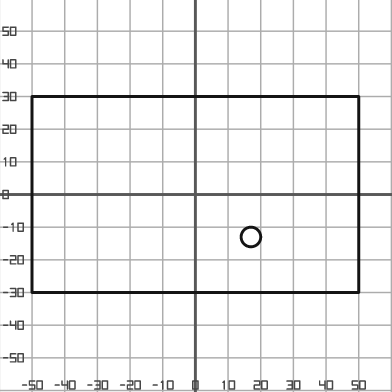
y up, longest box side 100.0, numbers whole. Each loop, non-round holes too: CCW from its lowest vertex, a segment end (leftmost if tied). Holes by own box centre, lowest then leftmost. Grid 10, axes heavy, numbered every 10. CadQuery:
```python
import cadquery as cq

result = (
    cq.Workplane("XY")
    .moveTo(-50.0, -30.0)
    .lineTo(50.0, -30.0)
    .lineTo(50.0, 30.0)
    .lineTo(-50.0, 30.0)
    .close()
    .moveTo(17.0, -13.0)
    .circle(3.0)
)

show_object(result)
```